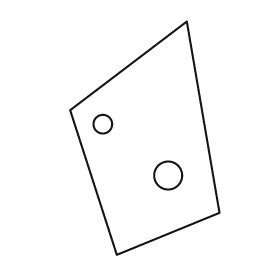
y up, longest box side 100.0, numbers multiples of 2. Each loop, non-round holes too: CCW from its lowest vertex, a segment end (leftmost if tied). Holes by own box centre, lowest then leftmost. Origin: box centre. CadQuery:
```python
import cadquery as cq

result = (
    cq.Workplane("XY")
    .moveTo(-12.0, -50.0)
    .lineTo(32.0, -32.0)
    .lineTo(18.0, 50.0)
    .lineTo(-32.0, 12.0)
    .close()
    .moveTo(10.0, -16.0)
    .circle(6.0)
    .moveTo(-18.0, 6.0)
    .circle(4.0)
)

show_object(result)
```